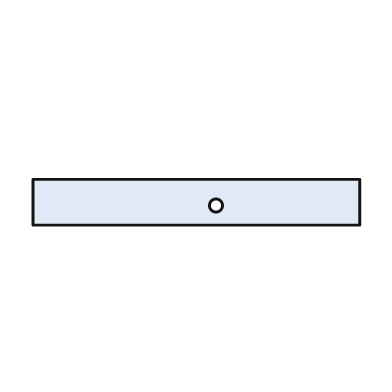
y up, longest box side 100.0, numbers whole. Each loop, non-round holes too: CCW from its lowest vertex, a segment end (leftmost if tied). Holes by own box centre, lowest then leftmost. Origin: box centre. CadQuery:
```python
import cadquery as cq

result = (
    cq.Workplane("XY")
    .moveTo(-50.0, -7.0)
    .lineTo(50.0, -7.0)
    .lineTo(50.0, 7.0)
    .lineTo(-50.0, 7.0)
    .close()
    .moveTo(6.0, -1.0)
    .circle(2.0)
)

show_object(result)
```